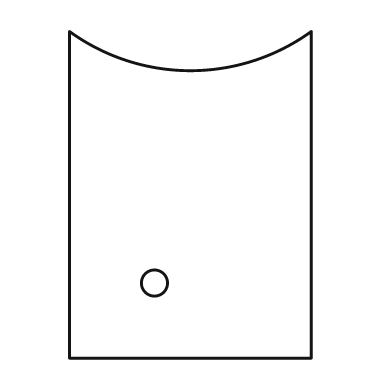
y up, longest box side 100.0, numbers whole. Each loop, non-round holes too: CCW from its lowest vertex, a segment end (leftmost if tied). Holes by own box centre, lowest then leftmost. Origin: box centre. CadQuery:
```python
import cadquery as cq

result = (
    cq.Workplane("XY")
    .moveTo(-37.0, -50.0)
    .lineTo(37.0, -50.0)
    .lineTo(37.0, 50.0)
    .threePointArc((0.0, 38.0), (-37.0, 50.0))
    .close()
    .moveTo(-11.0, -27.0)
    .circle(4.0)
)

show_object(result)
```